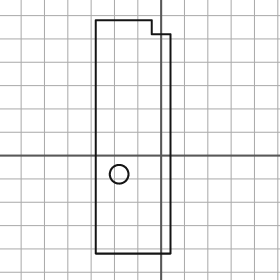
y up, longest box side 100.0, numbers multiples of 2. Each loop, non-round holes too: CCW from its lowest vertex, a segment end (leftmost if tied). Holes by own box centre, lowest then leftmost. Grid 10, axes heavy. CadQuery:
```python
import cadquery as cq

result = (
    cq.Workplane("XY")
    .moveTo(-28.0, -42.0)
    .lineTo(4.0, -42.0)
    .lineTo(4.0, 52.0)
    .lineTo(-4.0, 52.0)
    .lineTo(-4.0, 58.0)
    .lineTo(-28.0, 58.0)
    .close()
    .moveTo(-18.0, -8.0)
    .circle(4.0)
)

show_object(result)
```